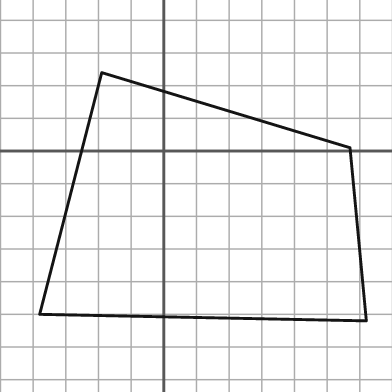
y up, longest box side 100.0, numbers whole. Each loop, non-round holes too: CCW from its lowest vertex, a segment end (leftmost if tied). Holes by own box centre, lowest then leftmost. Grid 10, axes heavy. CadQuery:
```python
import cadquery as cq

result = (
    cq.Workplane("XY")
    .moveTo(62.0, -52.0)
    .lineTo(57.0, 1.0)
    .lineTo(-19.0, 24.0)
    .lineTo(-38.0, -50.0)
    .close()
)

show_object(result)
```